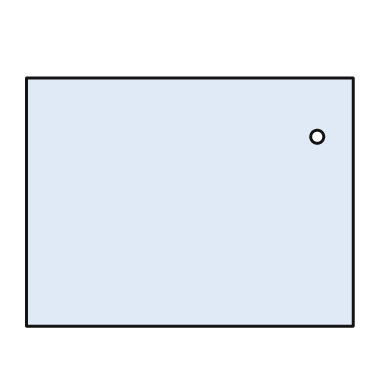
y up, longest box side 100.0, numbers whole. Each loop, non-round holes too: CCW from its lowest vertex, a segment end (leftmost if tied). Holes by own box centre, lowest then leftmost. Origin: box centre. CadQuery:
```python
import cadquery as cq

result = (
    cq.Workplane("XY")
    .moveTo(-50.0, -38.0)
    .lineTo(50.0, -38.0)
    .lineTo(50.0, 38.0)
    .lineTo(-50.0, 38.0)
    .close()
    .moveTo(39.0, 20.0)
    .circle(2.0)
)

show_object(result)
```